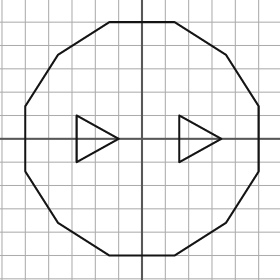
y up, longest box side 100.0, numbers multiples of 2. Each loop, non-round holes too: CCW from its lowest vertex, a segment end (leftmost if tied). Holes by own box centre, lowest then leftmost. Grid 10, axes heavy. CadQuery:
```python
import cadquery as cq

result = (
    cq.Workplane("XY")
    .moveTo(-14.0, -50.0)
    .lineTo(14.0, -50.0)
    .lineTo(36.0, -36.0)
    .lineTo(50.0, -14.0)
    .lineTo(50.0, 14.0)
    .lineTo(36.0, 36.0)
    .lineTo(14.0, 50.0)
    .lineTo(-14.0, 50.0)
    .lineTo(-36.0, 36.0)
    .lineTo(-50.0, 14.0)
    .lineTo(-50.0, -14.0)
    .lineTo(-36.0, -36.0)
    .close()
    .moveTo(-28.0, -10.0)
    .lineTo(-10.0, 0.0)
    .lineTo(-28.0, 10.0)
    .close()
    .moveTo(16.0, -10.0)
    .lineTo(34.0, 0.0)
    .lineTo(16.0, 10.0)
    .close()
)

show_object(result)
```